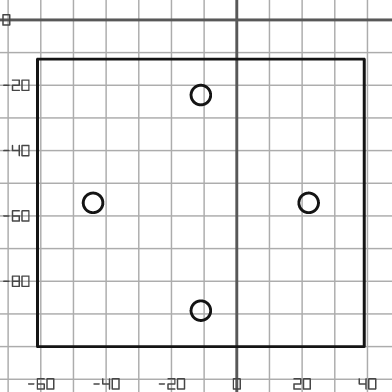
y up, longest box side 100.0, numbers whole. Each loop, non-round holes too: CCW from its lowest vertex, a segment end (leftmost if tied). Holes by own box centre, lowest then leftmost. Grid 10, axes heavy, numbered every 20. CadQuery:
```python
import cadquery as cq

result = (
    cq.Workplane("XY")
    .moveTo(-61.0, -100.0)
    .lineTo(39.0, -100.0)
    .lineTo(39.0, -12.0)
    .lineTo(-61.0, -12.0)
    .close()
    .moveTo(-11.0, -89.0)
    .circle(3.0)
    .moveTo(-44.0, -56.0)
    .circle(3.0)
    .moveTo(22.0, -56.0)
    .circle(3.0)
    .moveTo(-11.0, -23.0)
    .circle(3.0)
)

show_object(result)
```